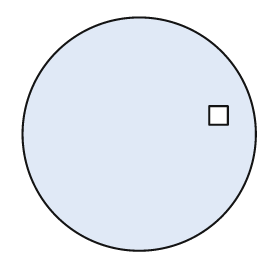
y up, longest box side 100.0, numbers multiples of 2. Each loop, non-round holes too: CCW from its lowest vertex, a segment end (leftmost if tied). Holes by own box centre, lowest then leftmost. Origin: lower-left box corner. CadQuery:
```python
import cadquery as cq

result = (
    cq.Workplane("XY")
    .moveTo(50.0, 50.0)
    .circle(50.0)
    .moveTo(80.0, 54.0)
    .lineTo(88.0, 54.0)
    .lineTo(88.0, 62.0)
    .lineTo(80.0, 62.0)
    .close()
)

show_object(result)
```